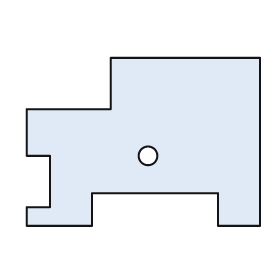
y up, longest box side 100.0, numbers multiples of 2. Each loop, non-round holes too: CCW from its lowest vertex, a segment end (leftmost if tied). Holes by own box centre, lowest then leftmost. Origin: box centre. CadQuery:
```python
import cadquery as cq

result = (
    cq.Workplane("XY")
    .moveTo(-50.0, -36.0)
    .lineTo(-22.0, -36.0)
    .lineTo(-22.0, -22.0)
    .lineTo(32.0, -22.0)
    .lineTo(32.0, -36.0)
    .lineTo(50.0, -36.0)
    .lineTo(50.0, 36.0)
    .lineTo(-14.0, 36.0)
    .lineTo(-14.0, 14.0)
    .lineTo(-50.0, 14.0)
    .lineTo(-50.0, -6.0)
    .lineTo(-40.0, -6.0)
    .lineTo(-40.0, -28.0)
    .lineTo(-50.0, -28.0)
    .close()
    .moveTo(2.0, -6.0)
    .circle(4.0)
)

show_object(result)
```